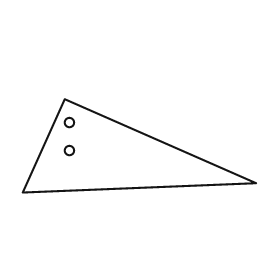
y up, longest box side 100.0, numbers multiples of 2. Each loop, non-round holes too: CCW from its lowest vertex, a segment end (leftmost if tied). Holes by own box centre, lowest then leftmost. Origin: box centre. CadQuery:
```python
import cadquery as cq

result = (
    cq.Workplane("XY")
    .moveTo(-50.0, -20.0)
    .lineTo(50.0, -16.0)
    .lineTo(-32.0, 20.0)
    .close()
    .moveTo(-30.0, -2.0)
    .circle(2.0)
    .moveTo(-30.0, 10.0)
    .circle(2.0)
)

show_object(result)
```